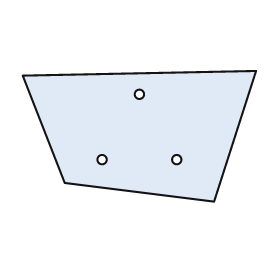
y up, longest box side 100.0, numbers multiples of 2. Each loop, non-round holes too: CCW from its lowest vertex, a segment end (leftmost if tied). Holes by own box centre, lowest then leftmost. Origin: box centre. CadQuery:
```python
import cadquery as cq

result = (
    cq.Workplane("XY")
    .moveTo(32.0, -28.0)
    .lineTo(50.0, 28.0)
    .lineTo(-50.0, 26.0)
    .lineTo(-32.0, -20.0)
    .close()
    .moveTo(-16.0, -10.0)
    .circle(2.0)
    .moveTo(16.0, -10.0)
    .circle(2.0)
    .moveTo(0.0, 18.0)
    .circle(2.0)
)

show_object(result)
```